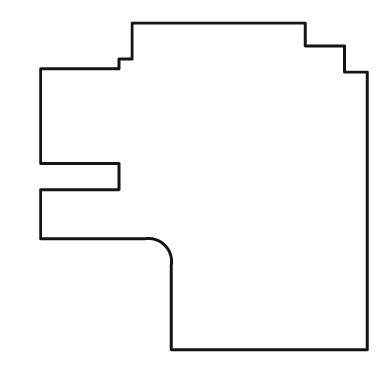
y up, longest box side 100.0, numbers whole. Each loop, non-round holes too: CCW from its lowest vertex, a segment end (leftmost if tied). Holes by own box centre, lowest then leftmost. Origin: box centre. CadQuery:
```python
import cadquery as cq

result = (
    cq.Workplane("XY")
    .moveTo(-10.0, -50.0)
    .lineTo(50.0, -50.0)
    .lineTo(50.0, 35.0)
    .lineTo(43.0, 35.0)
    .lineTo(43.0, 43.0)
    .lineTo(31.0, 43.0)
    .lineTo(31.0, 50.0)
    .lineTo(-22.0, 50.0)
    .lineTo(-22.0, 39.0)
    .lineTo(-26.0, 39.0)
    .lineTo(-26.0, 36.0)
    .lineTo(-50.0, 36.0)
    .lineTo(-50.0, 7.0)
    .lineTo(-26.0, 7.0)
    .lineTo(-26.0, -1.0)
    .lineTo(-50.0, -1.0)
    .lineTo(-50.0, -16.0)
    .lineTo(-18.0, -16.0)
    .threePointArc((-12.0, -18.0), (-10.0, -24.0))
    .close()
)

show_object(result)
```